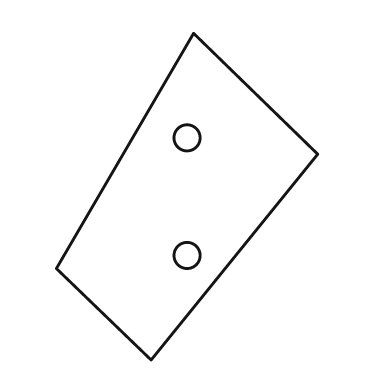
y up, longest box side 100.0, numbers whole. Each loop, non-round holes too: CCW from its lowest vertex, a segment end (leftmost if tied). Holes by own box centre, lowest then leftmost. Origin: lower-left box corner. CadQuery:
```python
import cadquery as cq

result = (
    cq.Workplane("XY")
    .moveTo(29.0, 0.0)
    .lineTo(80.0, 63.0)
    .lineTo(42.0, 100.0)
    .lineTo(0.0, 28.0)
    .close()
    .moveTo(40.0, 32.0)
    .circle(4.0)
    .moveTo(40.0, 68.0)
    .circle(4.0)
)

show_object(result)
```